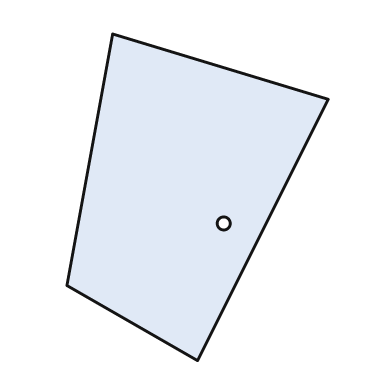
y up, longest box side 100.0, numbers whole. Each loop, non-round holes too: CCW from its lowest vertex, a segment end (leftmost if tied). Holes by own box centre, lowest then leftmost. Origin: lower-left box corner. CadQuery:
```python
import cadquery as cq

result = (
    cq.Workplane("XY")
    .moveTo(40.0, 0.0)
    .lineTo(80.0, 80.0)
    .lineTo(14.0, 100.0)
    .lineTo(0.0, 23.0)
    .close()
    .moveTo(48.0, 42.0)
    .circle(2.0)
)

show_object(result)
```